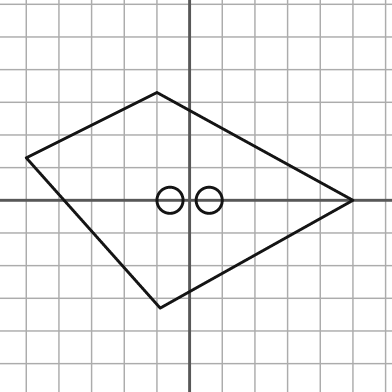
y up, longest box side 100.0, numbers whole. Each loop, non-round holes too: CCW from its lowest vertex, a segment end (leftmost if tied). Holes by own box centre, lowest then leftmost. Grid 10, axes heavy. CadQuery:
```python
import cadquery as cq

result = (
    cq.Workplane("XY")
    .moveTo(-9.0, -33.0)
    .lineTo(50.0, 0.0)
    .lineTo(-10.0, 33.0)
    .lineTo(-50.0, 13.0)
    .close()
    .moveTo(-6.0, 0.0)
    .circle(4.0)
    .moveTo(6.0, 0.0)
    .circle(4.0)
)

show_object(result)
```